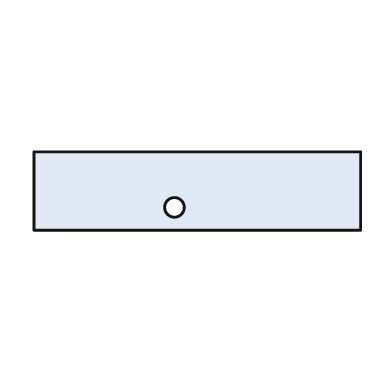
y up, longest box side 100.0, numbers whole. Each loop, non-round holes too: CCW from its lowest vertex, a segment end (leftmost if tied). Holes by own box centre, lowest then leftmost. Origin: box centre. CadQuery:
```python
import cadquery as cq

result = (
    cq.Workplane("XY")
    .moveTo(-50.0, -12.0)
    .lineTo(50.0, -12.0)
    .lineTo(50.0, 12.0)
    .lineTo(-50.0, 12.0)
    .close()
    .moveTo(-7.0, -5.0)
    .circle(3.0)
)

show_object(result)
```